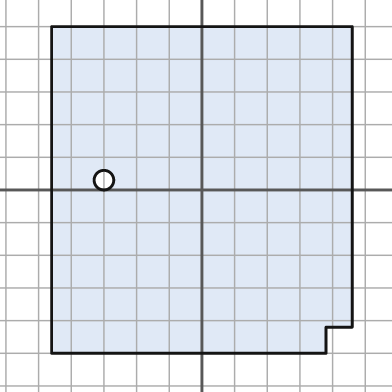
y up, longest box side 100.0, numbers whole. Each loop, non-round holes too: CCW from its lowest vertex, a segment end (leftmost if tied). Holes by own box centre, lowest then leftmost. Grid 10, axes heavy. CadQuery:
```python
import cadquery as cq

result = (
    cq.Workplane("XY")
    .moveTo(-46.0, -50.0)
    .lineTo(38.0, -50.0)
    .lineTo(38.0, -42.0)
    .lineTo(46.0, -42.0)
    .lineTo(46.0, 50.0)
    .lineTo(-46.0, 50.0)
    .close()
    .moveTo(-30.0, 3.0)
    .circle(3.0)
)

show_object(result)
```